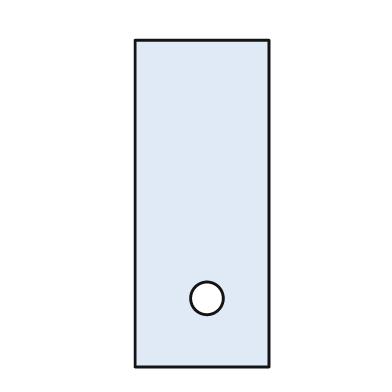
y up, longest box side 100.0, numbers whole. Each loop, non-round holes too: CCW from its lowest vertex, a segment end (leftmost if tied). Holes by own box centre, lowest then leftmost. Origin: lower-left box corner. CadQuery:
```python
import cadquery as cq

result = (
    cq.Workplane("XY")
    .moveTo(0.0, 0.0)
    .lineTo(41.0, 0.0)
    .lineTo(41.0, 100.0)
    .lineTo(0.0, 100.0)
    .close()
    .moveTo(22.0, 21.0)
    .circle(5.0)
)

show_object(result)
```